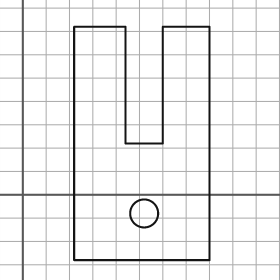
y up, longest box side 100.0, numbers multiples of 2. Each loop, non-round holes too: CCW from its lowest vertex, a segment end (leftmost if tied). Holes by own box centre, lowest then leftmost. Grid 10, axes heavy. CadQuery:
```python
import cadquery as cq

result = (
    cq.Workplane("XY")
    .moveTo(22.0, -28.0)
    .lineTo(80.0, -28.0)
    .lineTo(80.0, 72.0)
    .lineTo(60.0, 72.0)
    .lineTo(60.0, 22.0)
    .lineTo(44.0, 22.0)
    .lineTo(44.0, 72.0)
    .lineTo(22.0, 72.0)
    .close()
    .moveTo(52.0, -8.0)
    .circle(6.0)
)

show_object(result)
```